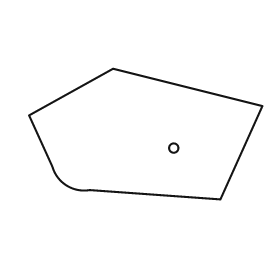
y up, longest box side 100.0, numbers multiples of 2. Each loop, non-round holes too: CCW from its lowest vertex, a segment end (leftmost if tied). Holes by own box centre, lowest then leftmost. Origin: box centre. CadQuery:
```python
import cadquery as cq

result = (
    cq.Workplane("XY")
    .moveTo(32.0, -28.0)
    .lineTo(50.0, 12.0)
    .lineTo(-14.0, 28.0)
    .lineTo(-50.0, 8.0)
    .lineTo(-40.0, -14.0)
    .threePointArc((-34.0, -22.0), (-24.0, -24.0))
    .close()
    .moveTo(12.0, -6.0)
    .circle(2.0)
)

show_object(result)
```